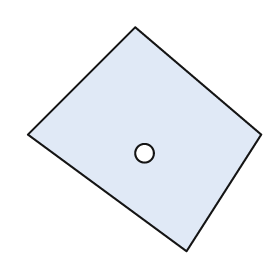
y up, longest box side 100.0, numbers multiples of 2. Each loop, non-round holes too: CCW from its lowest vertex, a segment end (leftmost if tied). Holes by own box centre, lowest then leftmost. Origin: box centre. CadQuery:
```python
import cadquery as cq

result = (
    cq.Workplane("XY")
    .moveTo(18.0, -48.0)
    .lineTo(50.0, 2.0)
    .lineTo(-4.0, 48.0)
    .lineTo(-50.0, 2.0)
    .close()
    .moveTo(0.0, -6.0)
    .circle(4.0)
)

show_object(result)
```